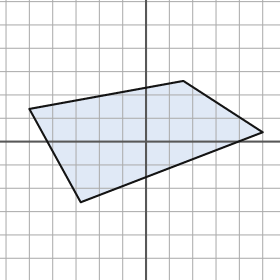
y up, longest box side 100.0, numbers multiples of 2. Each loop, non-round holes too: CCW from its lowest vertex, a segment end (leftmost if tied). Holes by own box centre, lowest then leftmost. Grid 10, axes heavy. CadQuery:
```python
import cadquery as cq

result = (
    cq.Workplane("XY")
    .moveTo(-28.0, -26.0)
    .lineTo(50.0, 4.0)
    .lineTo(16.0, 26.0)
    .lineTo(-50.0, 14.0)
    .close()
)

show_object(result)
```